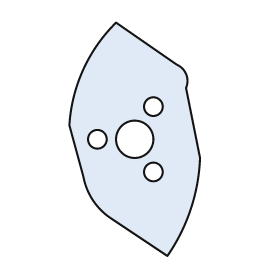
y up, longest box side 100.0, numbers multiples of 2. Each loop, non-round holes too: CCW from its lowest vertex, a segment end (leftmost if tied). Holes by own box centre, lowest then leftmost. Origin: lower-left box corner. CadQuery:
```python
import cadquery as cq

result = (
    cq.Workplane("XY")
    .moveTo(42.0, 0.0)
    .threePointArc((52.0, 20.0), (56.0, 42.0))
    .lineTo(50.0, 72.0)
    .threePointArc((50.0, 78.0), (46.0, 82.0))
    .lineTo(20.0, 100.0)
    .threePointArc((6.0, 80.0), (0.0, 56.0))
    .lineTo(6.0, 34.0)
    .threePointArc((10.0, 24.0), (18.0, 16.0))
    .close()
    .moveTo(36.0, 36.0)
    .circle(4.0)
    .moveTo(12.0, 50.0)
    .circle(4.0)
    .moveTo(28.0, 50.0)
    .circle(8.0)
    .moveTo(36.0, 64.0)
    .circle(4.0)
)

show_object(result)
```